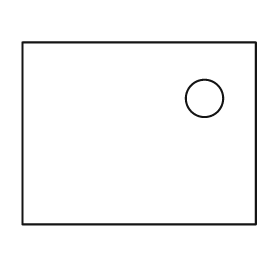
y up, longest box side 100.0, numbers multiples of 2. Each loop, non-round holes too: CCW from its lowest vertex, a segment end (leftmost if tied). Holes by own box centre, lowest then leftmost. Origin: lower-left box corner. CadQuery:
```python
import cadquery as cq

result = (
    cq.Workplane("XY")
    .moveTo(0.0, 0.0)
    .lineTo(100.0, 0.0)
    .lineTo(100.0, 78.0)
    .lineTo(0.0, 78.0)
    .close()
    .moveTo(78.0, 54.0)
    .circle(8.0)
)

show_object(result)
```